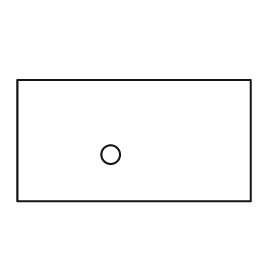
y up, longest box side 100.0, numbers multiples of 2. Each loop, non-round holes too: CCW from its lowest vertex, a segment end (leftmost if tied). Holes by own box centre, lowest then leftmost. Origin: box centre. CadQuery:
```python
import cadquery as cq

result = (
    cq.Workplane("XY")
    .moveTo(-50.0, -26.0)
    .lineTo(50.0, -26.0)
    .lineTo(50.0, 26.0)
    .lineTo(-50.0, 26.0)
    .close()
    .moveTo(-10.0, -6.0)
    .circle(4.0)
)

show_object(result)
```